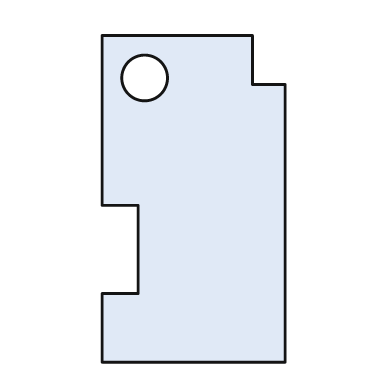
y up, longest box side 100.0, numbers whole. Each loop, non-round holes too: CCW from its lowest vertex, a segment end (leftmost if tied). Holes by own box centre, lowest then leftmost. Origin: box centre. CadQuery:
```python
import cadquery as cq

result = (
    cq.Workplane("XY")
    .moveTo(-28.0, -50.0)
    .lineTo(28.0, -50.0)
    .lineTo(28.0, 35.0)
    .lineTo(18.0, 35.0)
    .lineTo(18.0, 50.0)
    .lineTo(-28.0, 50.0)
    .lineTo(-28.0, -2.0)
    .lineTo(-17.0, -2.0)
    .lineTo(-17.0, -29.0)
    .lineTo(-28.0, -29.0)
    .close()
    .moveTo(-15.0, 37.0)
    .circle(7.0)
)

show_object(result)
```